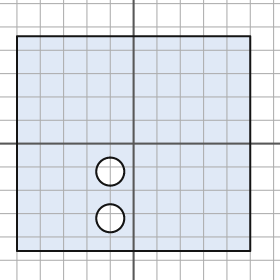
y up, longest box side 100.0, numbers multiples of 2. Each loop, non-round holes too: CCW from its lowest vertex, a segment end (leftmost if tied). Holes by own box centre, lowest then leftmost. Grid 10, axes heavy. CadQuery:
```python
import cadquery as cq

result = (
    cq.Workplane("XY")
    .moveTo(-50.0, -46.0)
    .lineTo(50.0, -46.0)
    .lineTo(50.0, 46.0)
    .lineTo(-50.0, 46.0)
    .close()
    .moveTo(-10.0, -32.0)
    .circle(6.0)
    .moveTo(-10.0, -12.0)
    .circle(6.0)
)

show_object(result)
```